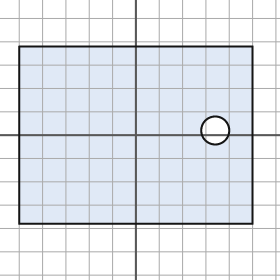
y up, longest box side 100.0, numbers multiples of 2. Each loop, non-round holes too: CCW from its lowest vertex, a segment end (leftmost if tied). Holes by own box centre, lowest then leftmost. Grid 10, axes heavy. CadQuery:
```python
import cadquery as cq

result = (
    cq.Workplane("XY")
    .moveTo(-50.0, -38.0)
    .lineTo(50.0, -38.0)
    .lineTo(50.0, 38.0)
    .lineTo(-50.0, 38.0)
    .close()
    .moveTo(34.0, 2.0)
    .circle(6.0)
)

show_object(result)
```